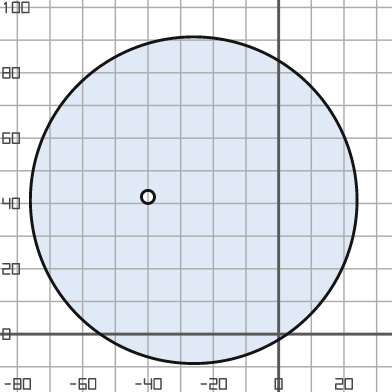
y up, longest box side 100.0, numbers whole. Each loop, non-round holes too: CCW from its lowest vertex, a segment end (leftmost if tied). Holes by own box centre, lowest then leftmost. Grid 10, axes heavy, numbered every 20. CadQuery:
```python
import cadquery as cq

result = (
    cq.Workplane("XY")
    .moveTo(-26.0, 41.0)
    .circle(50.0)
    .moveTo(-40.0, 42.0)
    .circle(2.0)
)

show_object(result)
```